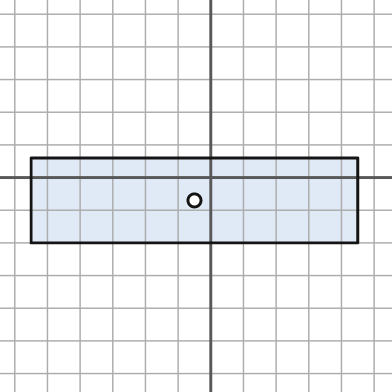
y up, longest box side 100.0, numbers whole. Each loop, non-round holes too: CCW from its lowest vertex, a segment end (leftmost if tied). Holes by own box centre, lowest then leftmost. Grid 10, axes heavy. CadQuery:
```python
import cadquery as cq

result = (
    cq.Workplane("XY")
    .moveTo(-55.0, -20.0)
    .lineTo(45.0, -20.0)
    .lineTo(45.0, 6.0)
    .lineTo(-55.0, 6.0)
    .close()
    .moveTo(-5.0, -7.0)
    .circle(2.0)
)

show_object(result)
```